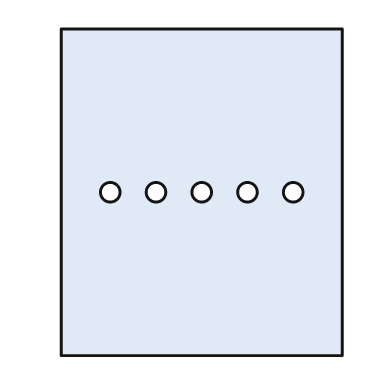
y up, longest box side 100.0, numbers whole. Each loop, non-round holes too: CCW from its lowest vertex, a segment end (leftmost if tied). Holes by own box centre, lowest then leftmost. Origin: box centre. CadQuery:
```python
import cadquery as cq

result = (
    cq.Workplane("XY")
    .moveTo(-43.0, -50.0)
    .lineTo(43.0, -50.0)
    .lineTo(43.0, 50.0)
    .lineTo(-43.0, 50.0)
    .close()
    .moveTo(-28.0, 0.0)
    .circle(3.0)
    .moveTo(-14.0, 0.0)
    .circle(3.0)
    .moveTo(0.0, 0.0)
    .circle(3.0)
    .moveTo(14.0, 0.0)
    .circle(3.0)
    .moveTo(28.0, 0.0)
    .circle(3.0)
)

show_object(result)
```